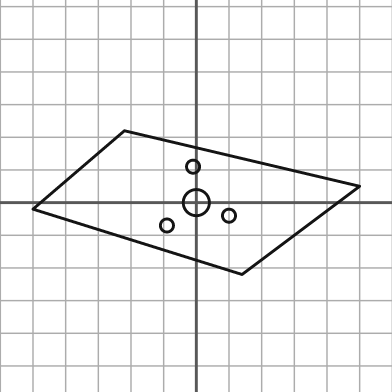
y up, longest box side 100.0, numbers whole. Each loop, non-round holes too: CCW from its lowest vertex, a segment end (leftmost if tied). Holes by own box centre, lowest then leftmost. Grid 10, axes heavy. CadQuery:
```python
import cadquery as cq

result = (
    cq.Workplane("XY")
    .moveTo(14.0, -22.0)
    .lineTo(50.0, 5.0)
    .lineTo(-22.0, 22.0)
    .lineTo(-50.0, -2.0)
    .close()
    .moveTo(-9.0, -7.0)
    .circle(2.0)
    .moveTo(10.0, -4.0)
    .circle(2.0)
    .moveTo(0.0, 0.0)
    .circle(4.0)
    .moveTo(-1.0, 11.0)
    .circle(2.0)
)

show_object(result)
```